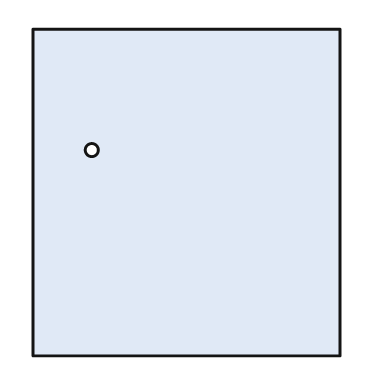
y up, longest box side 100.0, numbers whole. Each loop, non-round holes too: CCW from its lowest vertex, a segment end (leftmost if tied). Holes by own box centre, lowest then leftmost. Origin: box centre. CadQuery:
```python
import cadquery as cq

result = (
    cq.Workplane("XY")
    .moveTo(-47.0, -50.0)
    .lineTo(47.0, -50.0)
    .lineTo(47.0, 50.0)
    .lineTo(-47.0, 50.0)
    .close()
    .moveTo(-29.0, 13.0)
    .circle(2.0)
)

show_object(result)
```